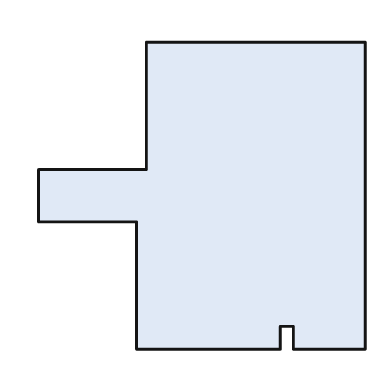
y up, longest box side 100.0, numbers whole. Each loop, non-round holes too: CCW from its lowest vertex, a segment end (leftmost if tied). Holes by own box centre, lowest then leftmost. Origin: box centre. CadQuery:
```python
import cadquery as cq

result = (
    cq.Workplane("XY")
    .moveTo(-20.0, -47.0)
    .lineTo(24.0, -47.0)
    .lineTo(24.0, -40.0)
    .lineTo(28.0, -40.0)
    .lineTo(28.0, -47.0)
    .lineTo(50.0, -47.0)
    .lineTo(50.0, 47.0)
    .lineTo(-17.0, 47.0)
    .lineTo(-17.0, 8.0)
    .lineTo(-50.0, 8.0)
    .lineTo(-50.0, -8.0)
    .lineTo(-20.0, -8.0)
    .close()
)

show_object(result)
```